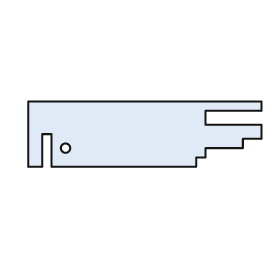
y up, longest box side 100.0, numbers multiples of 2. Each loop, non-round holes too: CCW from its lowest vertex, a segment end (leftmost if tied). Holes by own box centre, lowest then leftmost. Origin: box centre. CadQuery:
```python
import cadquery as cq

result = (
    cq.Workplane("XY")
    .moveTo(-50.0, -14.0)
    .lineTo(-44.0, -14.0)
    .lineTo(-44.0, 0.0)
    .lineTo(-40.0, 0.0)
    .lineTo(-40.0, -14.0)
    .lineTo(22.0, -14.0)
    .lineTo(22.0, -10.0)
    .lineTo(26.0, -10.0)
    .lineTo(26.0, -6.0)
    .lineTo(42.0, -6.0)
    .lineTo(42.0, -2.0)
    .lineTo(50.0, -2.0)
    .lineTo(50.0, 4.0)
    .lineTo(26.0, 4.0)
    .lineTo(26.0, 10.0)
    .lineTo(50.0, 10.0)
    .lineTo(50.0, 14.0)
    .lineTo(-50.0, 14.0)
    .close()
    .moveTo(-34.0, -6.0)
    .circle(2.0)
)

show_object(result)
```